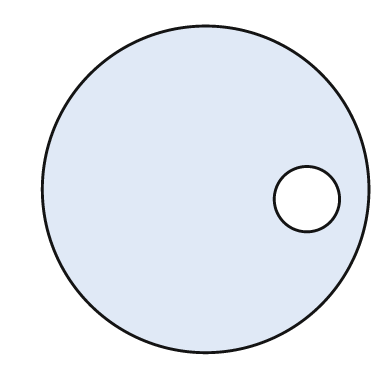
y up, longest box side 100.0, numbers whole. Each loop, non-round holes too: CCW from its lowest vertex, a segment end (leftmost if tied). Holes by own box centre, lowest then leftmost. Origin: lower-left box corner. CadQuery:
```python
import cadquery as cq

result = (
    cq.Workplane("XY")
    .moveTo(50.0, 50.0)
    .circle(50.0)
    .moveTo(81.0, 47.0)
    .circle(10.0)
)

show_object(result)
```